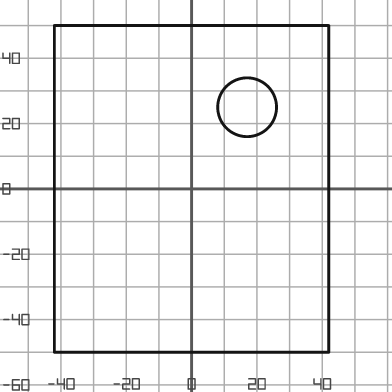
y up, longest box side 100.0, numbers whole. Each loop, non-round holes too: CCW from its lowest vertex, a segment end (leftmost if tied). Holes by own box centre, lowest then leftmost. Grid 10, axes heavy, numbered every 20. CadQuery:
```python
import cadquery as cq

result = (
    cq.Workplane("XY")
    .moveTo(-42.0, -50.0)
    .lineTo(42.0, -50.0)
    .lineTo(42.0, 50.0)
    .lineTo(-42.0, 50.0)
    .close()
    .moveTo(17.0, 25.0)
    .circle(9.0)
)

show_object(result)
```